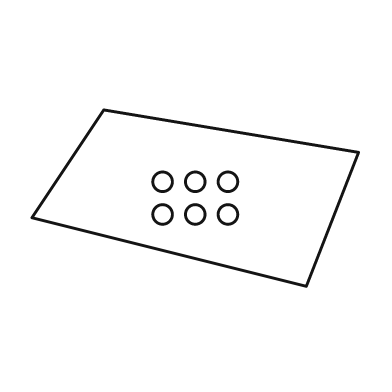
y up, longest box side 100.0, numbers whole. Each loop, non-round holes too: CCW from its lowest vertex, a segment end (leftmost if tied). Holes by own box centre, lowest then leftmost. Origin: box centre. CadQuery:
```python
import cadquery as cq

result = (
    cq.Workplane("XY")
    .moveTo(34.0, -27.0)
    .lineTo(50.0, 14.0)
    .lineTo(-28.0, 27.0)
    .lineTo(-50.0, -6.0)
    .close()
    .moveTo(-10.0, -5.0)
    .circle(3.0)
    .moveTo(0.0, -5.0)
    .circle(3.0)
    .moveTo(10.0, -5.0)
    .circle(3.0)
    .moveTo(-10.0, 5.0)
    .circle(3.0)
    .moveTo(0.0, 5.0)
    .circle(3.0)
    .moveTo(10.0, 5.0)
    .circle(3.0)
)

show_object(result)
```